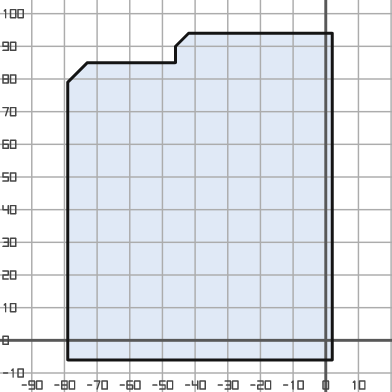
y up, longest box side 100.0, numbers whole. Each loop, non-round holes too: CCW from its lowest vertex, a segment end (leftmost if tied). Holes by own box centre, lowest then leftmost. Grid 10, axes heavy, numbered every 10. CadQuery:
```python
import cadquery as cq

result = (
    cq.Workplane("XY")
    .moveTo(-79.0, -6.0)
    .lineTo(2.0, -6.0)
    .lineTo(2.0, 94.0)
    .lineTo(-42.0, 94.0)
    .lineTo(-46.0, 90.0)
    .lineTo(-46.0, 85.0)
    .lineTo(-73.0, 85.0)
    .lineTo(-79.0, 79.0)
    .close()
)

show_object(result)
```